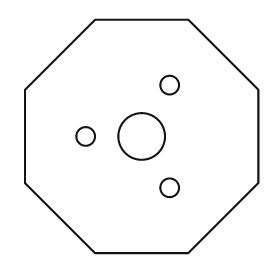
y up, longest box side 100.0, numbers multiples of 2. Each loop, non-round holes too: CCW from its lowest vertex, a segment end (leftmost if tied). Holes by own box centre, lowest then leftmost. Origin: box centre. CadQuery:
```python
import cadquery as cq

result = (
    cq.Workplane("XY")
    .moveTo(-20.0, -50.0)
    .lineTo(20.0, -50.0)
    .lineTo(50.0, -20.0)
    .lineTo(50.0, 20.0)
    .lineTo(20.0, 50.0)
    .lineTo(-20.0, 50.0)
    .lineTo(-50.0, 20.0)
    .lineTo(-50.0, -20.0)
    .close()
    .moveTo(12.0, -22.0)
    .circle(4.0)
    .moveTo(-24.0, 0.0)
    .circle(4.0)
    .moveTo(0.0, 0.0)
    .circle(10.0)
    .moveTo(12.0, 22.0)
    .circle(4.0)
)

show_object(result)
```